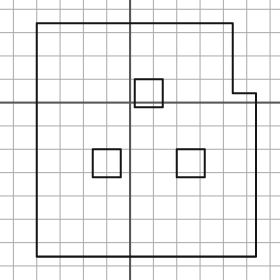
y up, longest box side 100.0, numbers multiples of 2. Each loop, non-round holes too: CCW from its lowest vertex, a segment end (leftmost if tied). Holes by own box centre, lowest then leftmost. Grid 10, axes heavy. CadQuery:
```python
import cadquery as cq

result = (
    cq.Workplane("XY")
    .moveTo(-40.0, -66.0)
    .lineTo(54.0, -66.0)
    .lineTo(54.0, 4.0)
    .lineTo(44.0, 4.0)
    .lineTo(44.0, 34.0)
    .lineTo(-40.0, 34.0)
    .close()
    .moveTo(-16.0, -32.0)
    .lineTo(-4.0, -32.0)
    .lineTo(-4.0, -20.0)
    .lineTo(-16.0, -20.0)
    .close()
    .moveTo(20.0, -32.0)
    .lineTo(32.0, -32.0)
    .lineTo(32.0, -20.0)
    .lineTo(20.0, -20.0)
    .close()
    .moveTo(2.0, -2.0)
    .lineTo(14.0, -2.0)
    .lineTo(14.0, 10.0)
    .lineTo(2.0, 10.0)
    .close()
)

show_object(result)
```